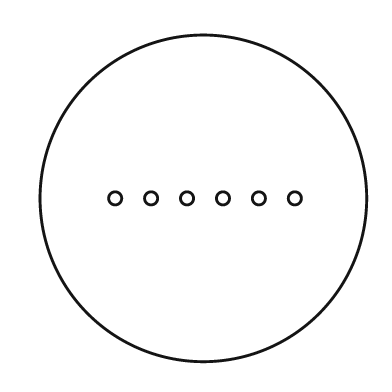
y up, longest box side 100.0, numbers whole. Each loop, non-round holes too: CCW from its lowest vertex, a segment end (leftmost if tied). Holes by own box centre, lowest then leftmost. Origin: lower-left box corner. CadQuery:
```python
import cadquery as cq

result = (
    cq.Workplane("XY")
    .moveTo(50.0, 50.0)
    .circle(50.0)
    .moveTo(23.0, 50.0)
    .circle(2.0)
    .moveTo(34.0, 50.0)
    .circle(2.0)
    .moveTo(45.0, 50.0)
    .circle(2.0)
    .moveTo(56.0, 50.0)
    .circle(2.0)
    .moveTo(67.0, 50.0)
    .circle(2.0)
    .moveTo(78.0, 50.0)
    .circle(2.0)
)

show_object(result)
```